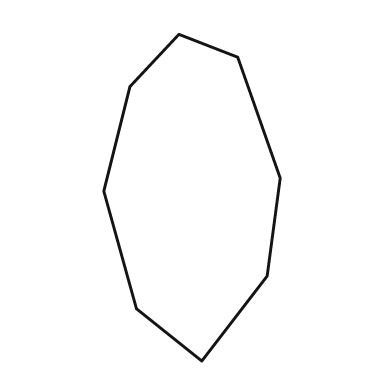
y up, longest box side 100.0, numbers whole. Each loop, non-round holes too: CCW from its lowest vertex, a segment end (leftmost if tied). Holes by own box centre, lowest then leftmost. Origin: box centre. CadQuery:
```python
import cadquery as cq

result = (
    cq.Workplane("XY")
    .moveTo(3.0, -50.0)
    .lineTo(23.0, -24.0)
    .lineTo(27.0, 6.0)
    .lineTo(14.0, 43.0)
    .lineTo(-4.0, 50.0)
    .lineTo(-19.0, 34.0)
    .lineTo(-27.0, 2.0)
    .lineTo(-17.0, -34.0)
    .close()
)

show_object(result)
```